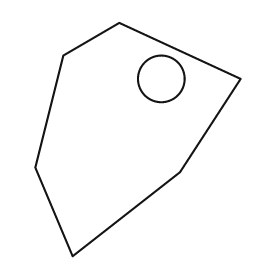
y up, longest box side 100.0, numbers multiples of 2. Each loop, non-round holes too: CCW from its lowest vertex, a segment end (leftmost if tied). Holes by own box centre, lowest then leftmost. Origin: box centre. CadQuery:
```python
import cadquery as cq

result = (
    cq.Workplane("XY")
    .moveTo(-28.0, -50.0)
    .lineTo(18.0, -14.0)
    .lineTo(44.0, 26.0)
    .lineTo(-8.0, 50.0)
    .lineTo(-32.0, 36.0)
    .lineTo(-44.0, -12.0)
    .close()
    .moveTo(10.0, 26.0)
    .circle(10.0)
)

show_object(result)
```